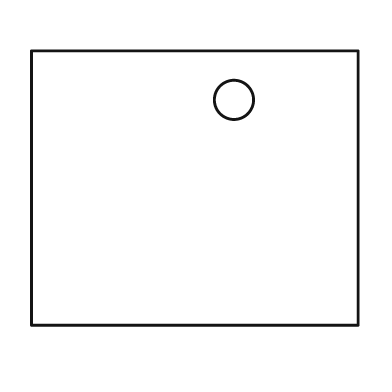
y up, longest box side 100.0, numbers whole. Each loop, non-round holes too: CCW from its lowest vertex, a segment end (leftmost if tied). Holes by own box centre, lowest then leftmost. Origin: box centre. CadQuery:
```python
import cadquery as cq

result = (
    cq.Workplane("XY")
    .moveTo(-50.0, -42.0)
    .lineTo(50.0, -42.0)
    .lineTo(50.0, 42.0)
    .lineTo(-50.0, 42.0)
    .close()
    .moveTo(12.0, 27.0)
    .circle(6.0)
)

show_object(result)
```